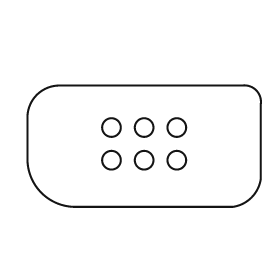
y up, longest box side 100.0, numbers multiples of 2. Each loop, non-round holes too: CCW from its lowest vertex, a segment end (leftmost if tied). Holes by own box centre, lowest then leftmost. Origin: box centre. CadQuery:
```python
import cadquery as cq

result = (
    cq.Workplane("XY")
    .moveTo(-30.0, -26.0)
    .lineTo(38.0, -26.0)
    .threePointArc((46.0, -22.0), (50.0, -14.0))
    .lineTo(50.0, 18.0)
    .threePointArc((48.0, 24.0), (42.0, 26.0))
    .lineTo(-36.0, 26.0)
    .threePointArc((-46.0, 22.0), (-50.0, 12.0))
    .lineTo(-50.0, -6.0)
    .threePointArc((-44.0, -20.0), (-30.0, -26.0))
    .close()
    .moveTo(-14.0, -6.0)
    .circle(4.0)
    .moveTo(0.0, -6.0)
    .circle(4.0)
    .moveTo(14.0, -6.0)
    .circle(4.0)
    .moveTo(-14.0, 8.0)
    .circle(4.0)
    .moveTo(0.0, 8.0)
    .circle(4.0)
    .moveTo(14.0, 8.0)
    .circle(4.0)
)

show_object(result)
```